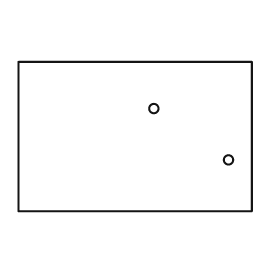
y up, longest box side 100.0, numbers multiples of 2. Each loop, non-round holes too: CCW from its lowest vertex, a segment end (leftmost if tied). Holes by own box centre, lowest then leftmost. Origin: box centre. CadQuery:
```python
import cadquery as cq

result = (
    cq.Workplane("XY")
    .moveTo(-50.0, -32.0)
    .lineTo(50.0, -32.0)
    .lineTo(50.0, 32.0)
    .lineTo(-50.0, 32.0)
    .close()
    .moveTo(40.0, -10.0)
    .circle(2.0)
    .moveTo(8.0, 12.0)
    .circle(2.0)
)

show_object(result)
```